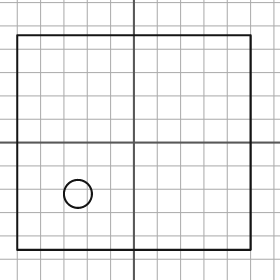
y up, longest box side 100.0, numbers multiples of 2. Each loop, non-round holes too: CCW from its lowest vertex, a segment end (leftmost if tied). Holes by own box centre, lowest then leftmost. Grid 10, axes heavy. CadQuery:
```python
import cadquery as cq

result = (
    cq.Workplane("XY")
    .moveTo(-50.0, -46.0)
    .lineTo(50.0, -46.0)
    .lineTo(50.0, 46.0)
    .lineTo(-50.0, 46.0)
    .close()
    .moveTo(-24.0, -22.0)
    .circle(6.0)
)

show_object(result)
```